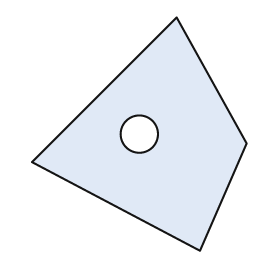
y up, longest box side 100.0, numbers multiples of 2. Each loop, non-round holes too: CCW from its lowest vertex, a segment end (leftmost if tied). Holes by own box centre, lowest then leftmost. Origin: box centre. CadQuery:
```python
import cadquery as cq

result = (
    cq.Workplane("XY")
    .moveTo(26.0, -50.0)
    .lineTo(46.0, -4.0)
    .lineTo(16.0, 50.0)
    .lineTo(-46.0, -12.0)
    .close()
    .moveTo(0.0, 0.0)
    .circle(8.0)
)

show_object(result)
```